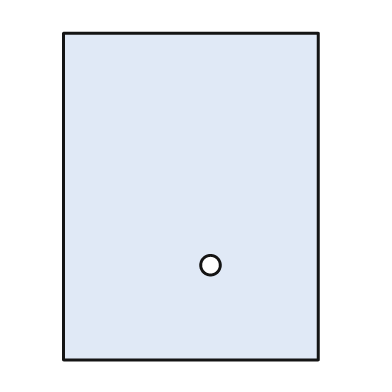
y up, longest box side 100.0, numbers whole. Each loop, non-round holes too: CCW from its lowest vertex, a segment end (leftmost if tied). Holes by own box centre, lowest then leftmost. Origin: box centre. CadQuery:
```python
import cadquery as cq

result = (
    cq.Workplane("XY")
    .moveTo(-39.0, -50.0)
    .lineTo(39.0, -50.0)
    .lineTo(39.0, 50.0)
    .lineTo(-39.0, 50.0)
    .close()
    .moveTo(6.0, -21.0)
    .circle(3.0)
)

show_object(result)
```